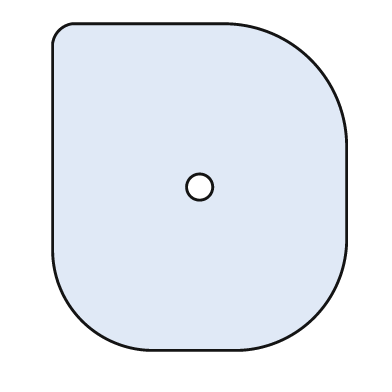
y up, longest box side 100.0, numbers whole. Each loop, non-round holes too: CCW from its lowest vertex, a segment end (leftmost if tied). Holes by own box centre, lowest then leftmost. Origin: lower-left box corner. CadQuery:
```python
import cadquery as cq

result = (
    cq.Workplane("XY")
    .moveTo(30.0, 0.0)
    .lineTo(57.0, 0.0)
    .threePointArc((80.0, 10.0), (90.0, 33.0))
    .lineTo(90.0, 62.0)
    .threePointArc((79.0, 89.0), (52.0, 100.0))
    .lineTo(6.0, 100.0)
    .threePointArc((2.0, 98.0), (0.0, 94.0))
    .lineTo(0.0, 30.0)
    .threePointArc((9.0, 9.0), (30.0, 0.0))
    .close()
    .moveTo(45.0, 50.0)
    .circle(4.0)
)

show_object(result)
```